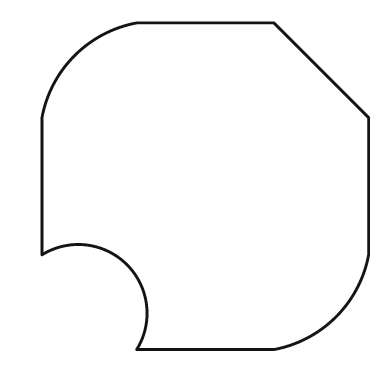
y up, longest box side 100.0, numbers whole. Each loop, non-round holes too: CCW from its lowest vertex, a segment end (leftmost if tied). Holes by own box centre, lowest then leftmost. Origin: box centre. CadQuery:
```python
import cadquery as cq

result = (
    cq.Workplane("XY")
    .moveTo(-21.0, -50.0)
    .lineTo(21.0, -50.0)
    .threePointArc((40.0, -40.0), (50.0, -21.0))
    .lineTo(50.0, 21.0)
    .lineTo(21.0, 50.0)
    .lineTo(-21.0, 50.0)
    .threePointArc((-40.0, 40.0), (-50.0, 21.0))
    .lineTo(-50.0, -21.0)
    .threePointArc((-24.0, -24.0), (-21.0, -50.0))
    .close()
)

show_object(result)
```